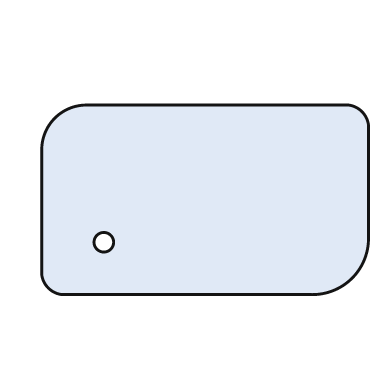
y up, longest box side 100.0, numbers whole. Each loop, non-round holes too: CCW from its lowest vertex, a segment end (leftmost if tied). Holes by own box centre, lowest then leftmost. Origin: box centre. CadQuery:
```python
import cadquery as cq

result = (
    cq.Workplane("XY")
    .moveTo(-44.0, -29.0)
    .lineTo(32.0, -29.0)
    .threePointArc((45.0, -24.0), (50.0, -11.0))
    .lineTo(50.0, 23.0)
    .threePointArc((48.0, 27.0), (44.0, 29.0))
    .lineTo(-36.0, 29.0)
    .threePointArc((-46.0, 25.0), (-50.0, 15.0))
    .lineTo(-50.0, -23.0)
    .threePointArc((-48.0, -27.0), (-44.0, -29.0))
    .close()
    .moveTo(-31.0, -13.0)
    .circle(3.0)
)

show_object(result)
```